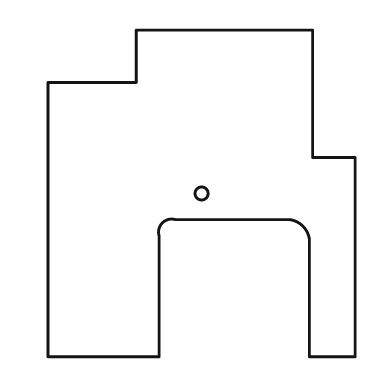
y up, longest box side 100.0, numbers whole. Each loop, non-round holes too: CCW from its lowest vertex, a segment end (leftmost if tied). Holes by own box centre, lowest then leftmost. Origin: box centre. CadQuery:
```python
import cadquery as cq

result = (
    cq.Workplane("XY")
    .moveTo(-47.0, -50.0)
    .lineTo(-13.0, -50.0)
    .lineTo(-13.0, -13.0)
    .threePointArc((-12.0, -9.0), (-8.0, -8.0))
    .lineTo(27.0, -8.0)
    .threePointArc((31.0, -10.0), (33.0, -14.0))
    .lineTo(33.0, -50.0)
    .lineTo(47.0, -50.0)
    .lineTo(47.0, 11.0)
    .lineTo(34.0, 11.0)
    .lineTo(34.0, 50.0)
    .lineTo(-20.0, 50.0)
    .lineTo(-20.0, 34.0)
    .lineTo(-47.0, 34.0)
    .close()
    .moveTo(0.0, 0.0)
    .circle(2.0)
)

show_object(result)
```